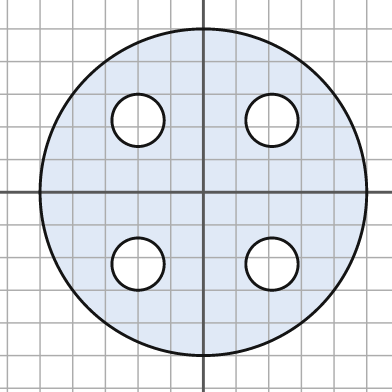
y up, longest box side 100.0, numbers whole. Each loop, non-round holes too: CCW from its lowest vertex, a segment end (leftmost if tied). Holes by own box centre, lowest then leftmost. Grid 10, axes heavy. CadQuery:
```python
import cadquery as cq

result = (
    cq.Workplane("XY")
    .moveTo(0.0, 0.0)
    .circle(50.0)
    .moveTo(-20.0, -22.0)
    .circle(8.0)
    .moveTo(21.0, -22.0)
    .circle(8.0)
    .moveTo(-20.0, 22.0)
    .circle(8.0)
    .moveTo(21.0, 22.0)
    .circle(8.0)
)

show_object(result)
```